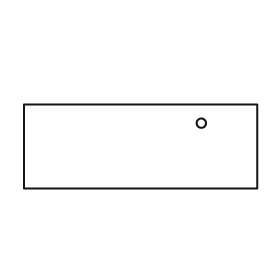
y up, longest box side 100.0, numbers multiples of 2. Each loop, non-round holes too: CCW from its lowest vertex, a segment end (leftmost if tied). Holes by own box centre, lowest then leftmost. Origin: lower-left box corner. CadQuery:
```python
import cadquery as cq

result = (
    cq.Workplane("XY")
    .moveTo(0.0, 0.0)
    .lineTo(100.0, 0.0)
    .lineTo(100.0, 36.0)
    .lineTo(0.0, 36.0)
    .close()
    .moveTo(76.0, 28.0)
    .circle(2.0)
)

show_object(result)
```